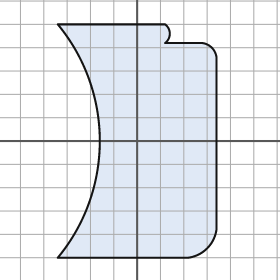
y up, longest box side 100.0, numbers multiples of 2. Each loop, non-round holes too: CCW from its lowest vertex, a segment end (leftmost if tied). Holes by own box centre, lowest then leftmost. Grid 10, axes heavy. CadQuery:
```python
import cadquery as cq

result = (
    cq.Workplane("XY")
    .moveTo(-34.0, -50.0)
    .lineTo(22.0, -50.0)
    .threePointArc((30.0, -46.0), (34.0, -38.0))
    .lineTo(34.0, 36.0)
    .threePointArc((32.0, 40.0), (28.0, 42.0))
    .lineTo(12.0, 42.0)
    .threePointArc((14.0, 46.0), (12.0, 50.0))
    .lineTo(-34.0, 50.0)
    .threePointArc((-16.0, 0.0), (-34.0, -50.0))
    .close()
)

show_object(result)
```